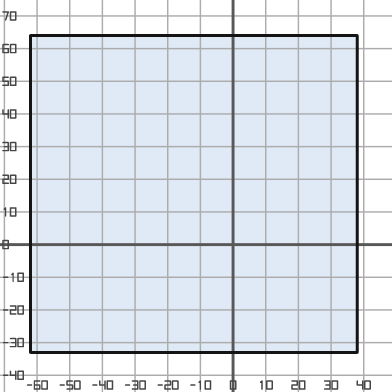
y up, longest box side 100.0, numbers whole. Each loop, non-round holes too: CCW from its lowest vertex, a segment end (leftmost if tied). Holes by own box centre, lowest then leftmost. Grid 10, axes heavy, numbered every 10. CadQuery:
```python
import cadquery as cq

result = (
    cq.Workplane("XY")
    .moveTo(-62.0, -33.0)
    .lineTo(38.0, -33.0)
    .lineTo(38.0, 64.0)
    .lineTo(-62.0, 64.0)
    .close()
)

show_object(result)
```